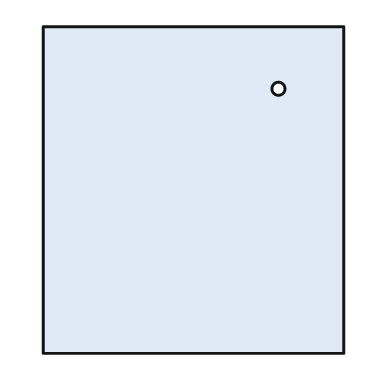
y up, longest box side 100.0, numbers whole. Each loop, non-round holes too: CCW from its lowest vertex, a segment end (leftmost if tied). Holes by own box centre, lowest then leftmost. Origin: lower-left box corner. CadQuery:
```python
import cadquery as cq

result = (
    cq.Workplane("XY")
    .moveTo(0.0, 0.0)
    .lineTo(92.0, 0.0)
    .lineTo(92.0, 100.0)
    .lineTo(0.0, 100.0)
    .close()
    .moveTo(72.0, 81.0)
    .circle(2.0)
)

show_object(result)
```